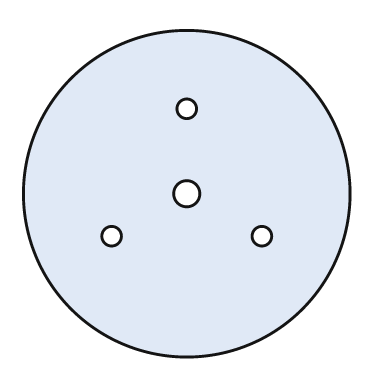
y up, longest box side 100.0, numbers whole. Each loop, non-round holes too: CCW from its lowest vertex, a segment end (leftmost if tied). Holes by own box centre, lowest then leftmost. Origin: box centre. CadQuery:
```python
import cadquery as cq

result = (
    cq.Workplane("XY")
    .moveTo(0.0, 0.0)
    .circle(50.0)
    .moveTo(-23.0, -13.0)
    .circle(3.0)
    .moveTo(23.0, -13.0)
    .circle(3.0)
    .moveTo(0.0, 0.0)
    .circle(4.0)
    .moveTo(0.0, 26.0)
    .circle(3.0)
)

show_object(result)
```